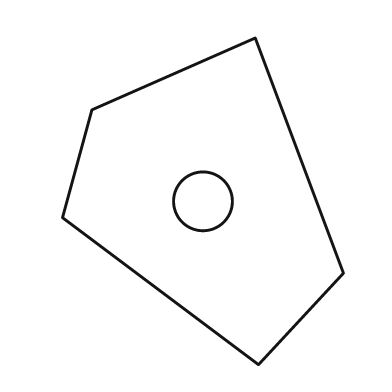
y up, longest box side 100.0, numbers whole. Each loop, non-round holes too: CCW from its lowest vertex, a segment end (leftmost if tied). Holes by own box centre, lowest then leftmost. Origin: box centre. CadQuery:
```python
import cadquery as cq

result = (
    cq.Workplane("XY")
    .moveTo(17.0, -50.0)
    .lineTo(43.0, -22.0)
    .lineTo(16.0, 50.0)
    .lineTo(-34.0, 28.0)
    .lineTo(-43.0, -5.0)
    .close()
    .moveTo(0.0, 0.0)
    .circle(9.0)
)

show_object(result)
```